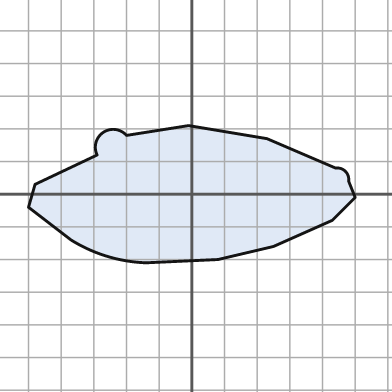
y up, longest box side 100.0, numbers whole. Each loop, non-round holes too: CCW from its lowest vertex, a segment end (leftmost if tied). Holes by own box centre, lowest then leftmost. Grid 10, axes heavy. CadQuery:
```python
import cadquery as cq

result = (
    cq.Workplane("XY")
    .moveTo(-14.0, -21.0)
    .lineTo(8.0, -20.0)
    .lineTo(25.0, -16.0)
    .lineTo(43.0, -8.0)
    .lineTo(50.0, -1.0)
    .lineTo(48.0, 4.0)
    .threePointArc((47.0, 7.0), (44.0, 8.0))
    .lineTo(23.0, 17.0)
    .lineTo(-1.0, 21.0)
    .lineTo(-20.0, 18.0)
    .threePointArc((-27.0, 19.0), (-29.0, 12.0))
    .lineTo(-48.0, 3.0)
    .lineTo(-50.0, -4.0)
    .lineTo(-37.0, -14.0)
    .threePointArc((-26.0, -19.0), (-14.0, -21.0))
    .close()
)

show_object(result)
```